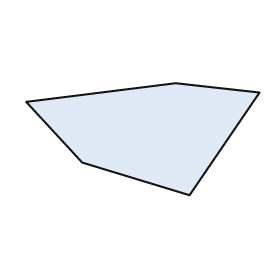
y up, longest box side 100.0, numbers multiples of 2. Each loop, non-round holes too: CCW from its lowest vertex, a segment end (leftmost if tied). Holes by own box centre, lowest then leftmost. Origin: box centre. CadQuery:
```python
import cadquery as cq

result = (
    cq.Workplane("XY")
    .moveTo(20.0, -24.0)
    .lineTo(50.0, 20.0)
    .lineTo(14.0, 24.0)
    .lineTo(-50.0, 16.0)
    .lineTo(-26.0, -10.0)
    .close()
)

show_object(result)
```